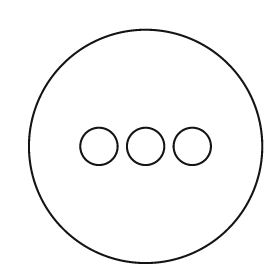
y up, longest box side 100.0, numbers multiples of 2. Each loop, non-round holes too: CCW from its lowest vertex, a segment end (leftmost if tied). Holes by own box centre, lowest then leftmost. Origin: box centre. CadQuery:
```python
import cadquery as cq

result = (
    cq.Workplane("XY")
    .moveTo(0.0, 0.0)
    .circle(50.0)
    .moveTo(-20.0, 0.0)
    .circle(8.0)
    .moveTo(0.0, 0.0)
    .circle(8.0)
    .moveTo(20.0, 0.0)
    .circle(8.0)
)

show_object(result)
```